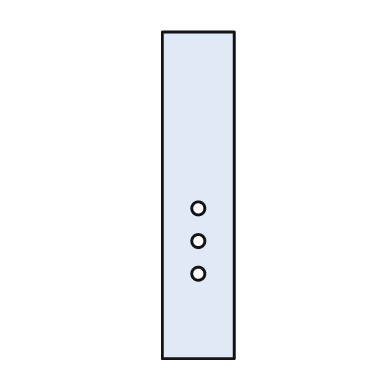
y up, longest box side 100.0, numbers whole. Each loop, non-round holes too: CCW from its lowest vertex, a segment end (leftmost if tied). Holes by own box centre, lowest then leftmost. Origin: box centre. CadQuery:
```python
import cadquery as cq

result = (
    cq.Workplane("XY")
    .moveTo(-11.0, -50.0)
    .lineTo(11.0, -50.0)
    .lineTo(11.0, 50.0)
    .lineTo(-11.0, 50.0)
    .close()
    .moveTo(0.0, -24.0)
    .circle(2.0)
    .moveTo(0.0, -14.0)
    .circle(2.0)
    .moveTo(0.0, -4.0)
    .circle(2.0)
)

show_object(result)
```